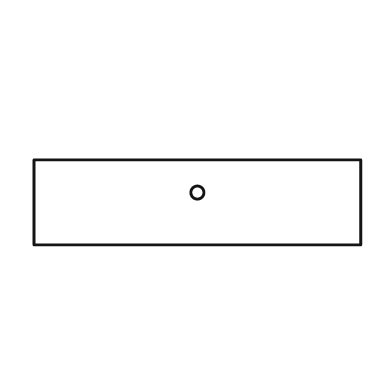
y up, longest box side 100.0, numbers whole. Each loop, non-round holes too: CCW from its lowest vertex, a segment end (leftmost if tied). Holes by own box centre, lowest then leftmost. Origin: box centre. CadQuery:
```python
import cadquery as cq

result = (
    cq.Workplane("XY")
    .moveTo(-50.0, -13.0)
    .lineTo(50.0, -13.0)
    .lineTo(50.0, 13.0)
    .lineTo(-50.0, 13.0)
    .close()
    .moveTo(0.0, 3.0)
    .circle(2.0)
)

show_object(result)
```